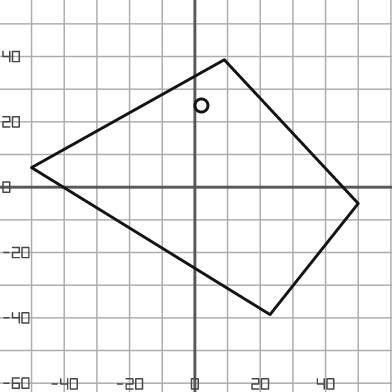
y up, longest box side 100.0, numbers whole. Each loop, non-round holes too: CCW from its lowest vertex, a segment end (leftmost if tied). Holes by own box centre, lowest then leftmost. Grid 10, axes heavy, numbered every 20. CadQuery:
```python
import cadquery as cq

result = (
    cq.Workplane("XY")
    .moveTo(23.0, -39.0)
    .lineTo(50.0, -5.0)
    .lineTo(9.0, 39.0)
    .lineTo(-50.0, 6.0)
    .close()
    .moveTo(2.0, 25.0)
    .circle(2.0)
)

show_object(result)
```